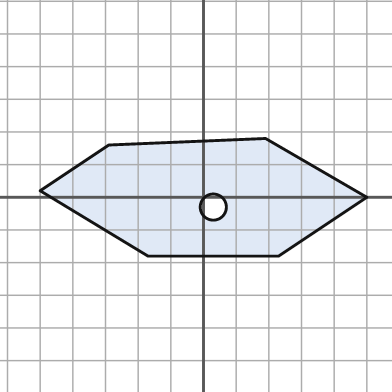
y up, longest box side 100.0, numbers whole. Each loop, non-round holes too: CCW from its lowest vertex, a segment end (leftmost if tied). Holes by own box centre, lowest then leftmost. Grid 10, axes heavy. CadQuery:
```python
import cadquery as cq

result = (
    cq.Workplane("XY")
    .moveTo(-17.0, -18.0)
    .lineTo(23.0, -18.0)
    .lineTo(50.0, 0.0)
    .lineTo(19.0, 18.0)
    .lineTo(-29.0, 16.0)
    .lineTo(-50.0, 2.0)
    .close()
    .moveTo(3.0, -3.0)
    .circle(4.0)
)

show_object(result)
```